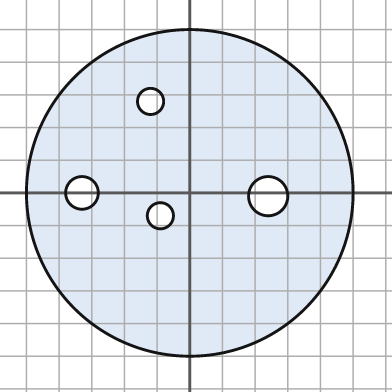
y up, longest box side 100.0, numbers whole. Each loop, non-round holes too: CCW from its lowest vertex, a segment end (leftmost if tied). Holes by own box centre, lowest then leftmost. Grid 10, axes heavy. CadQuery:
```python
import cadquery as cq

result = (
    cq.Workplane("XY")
    .moveTo(0.0, 0.0)
    .circle(50.0)
    .moveTo(-9.0, -7.0)
    .circle(4.0)
    .moveTo(24.0, -1.0)
    .circle(6.0)
    .moveTo(-33.0, 0.0)
    .circle(5.0)
    .moveTo(-12.0, 28.0)
    .circle(4.0)
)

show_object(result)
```